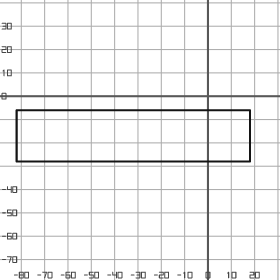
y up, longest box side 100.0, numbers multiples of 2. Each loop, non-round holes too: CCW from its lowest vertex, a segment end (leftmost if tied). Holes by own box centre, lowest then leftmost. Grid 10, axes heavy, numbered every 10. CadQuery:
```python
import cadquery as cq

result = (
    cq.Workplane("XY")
    .moveTo(-82.0, -28.0)
    .lineTo(18.0, -28.0)
    .lineTo(18.0, -6.0)
    .lineTo(-82.0, -6.0)
    .close()
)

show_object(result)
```